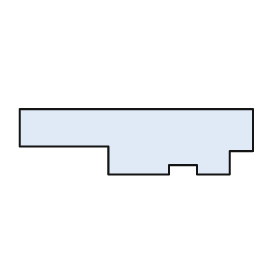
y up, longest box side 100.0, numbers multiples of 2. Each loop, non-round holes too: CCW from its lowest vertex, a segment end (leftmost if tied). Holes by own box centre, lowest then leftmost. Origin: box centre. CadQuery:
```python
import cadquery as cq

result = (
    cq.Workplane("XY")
    .moveTo(-12.0, -14.0)
    .lineTo(14.0, -14.0)
    .lineTo(14.0, -10.0)
    .lineTo(26.0, -10.0)
    .lineTo(26.0, -14.0)
    .lineTo(40.0, -14.0)
    .lineTo(40.0, -4.0)
    .lineTo(50.0, -4.0)
    .lineTo(50.0, 14.0)
    .lineTo(-50.0, 14.0)
    .lineTo(-50.0, -2.0)
    .lineTo(-12.0, -2.0)
    .close()
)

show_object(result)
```